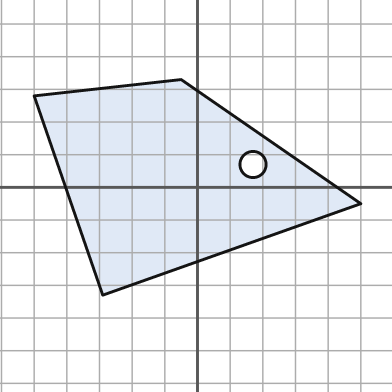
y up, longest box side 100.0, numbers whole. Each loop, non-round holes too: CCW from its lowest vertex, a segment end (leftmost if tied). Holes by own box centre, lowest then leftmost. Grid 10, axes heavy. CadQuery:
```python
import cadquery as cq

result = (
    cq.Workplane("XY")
    .moveTo(-29.0, -33.0)
    .lineTo(50.0, -5.0)
    .lineTo(-5.0, 33.0)
    .lineTo(-50.0, 28.0)
    .close()
    .moveTo(17.0, 7.0)
    .circle(4.0)
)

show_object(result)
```